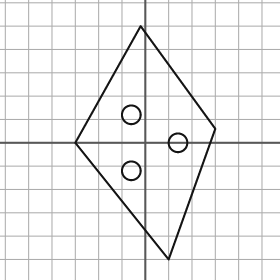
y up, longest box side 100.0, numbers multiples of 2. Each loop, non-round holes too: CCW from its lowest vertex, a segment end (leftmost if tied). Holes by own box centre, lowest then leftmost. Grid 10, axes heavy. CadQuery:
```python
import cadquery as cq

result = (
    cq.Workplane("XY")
    .moveTo(10.0, -50.0)
    .lineTo(30.0, 6.0)
    .lineTo(-2.0, 50.0)
    .lineTo(-30.0, 0.0)
    .close()
    .moveTo(-6.0, -12.0)
    .circle(4.0)
    .moveTo(14.0, 0.0)
    .circle(4.0)
    .moveTo(-6.0, 12.0)
    .circle(4.0)
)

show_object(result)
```